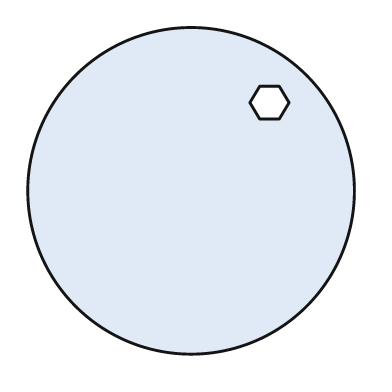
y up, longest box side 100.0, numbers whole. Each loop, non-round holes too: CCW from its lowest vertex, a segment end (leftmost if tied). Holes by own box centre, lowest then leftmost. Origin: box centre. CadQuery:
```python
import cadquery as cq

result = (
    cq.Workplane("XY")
    .moveTo(0.0, 0.0)
    .circle(50.0)
    .moveTo(21.0, 22.0)
    .lineTo(27.0, 22.0)
    .lineTo(30.0, 27.0)
    .lineTo(27.0, 32.0)
    .lineTo(21.0, 32.0)
    .lineTo(18.0, 27.0)
    .close()
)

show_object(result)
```